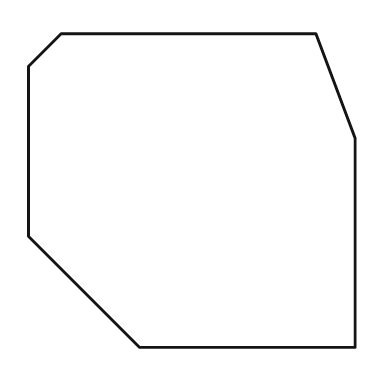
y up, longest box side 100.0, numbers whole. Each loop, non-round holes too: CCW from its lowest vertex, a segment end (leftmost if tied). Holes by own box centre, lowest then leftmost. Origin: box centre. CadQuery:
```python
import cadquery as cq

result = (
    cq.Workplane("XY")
    .moveTo(-16.0, -48.0)
    .lineTo(50.0, -48.0)
    .lineTo(50.0, 16.0)
    .lineTo(38.0, 48.0)
    .lineTo(-40.0, 48.0)
    .lineTo(-50.0, 38.0)
    .lineTo(-50.0, -14.0)
    .close()
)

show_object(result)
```